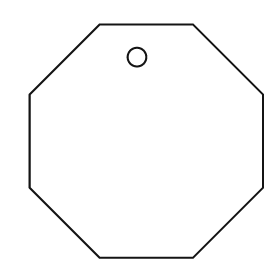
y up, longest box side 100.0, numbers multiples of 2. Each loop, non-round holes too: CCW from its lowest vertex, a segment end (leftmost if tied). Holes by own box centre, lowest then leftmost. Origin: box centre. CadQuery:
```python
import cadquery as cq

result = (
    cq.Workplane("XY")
    .moveTo(-20.0, -50.0)
    .lineTo(20.0, -50.0)
    .lineTo(50.0, -20.0)
    .lineTo(50.0, 20.0)
    .lineTo(20.0, 50.0)
    .lineTo(-20.0, 50.0)
    .lineTo(-50.0, 20.0)
    .lineTo(-50.0, -20.0)
    .close()
    .moveTo(-4.0, 36.0)
    .circle(4.0)
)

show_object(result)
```